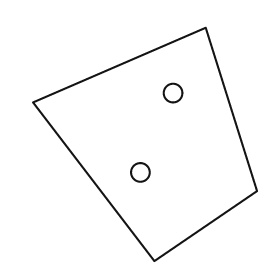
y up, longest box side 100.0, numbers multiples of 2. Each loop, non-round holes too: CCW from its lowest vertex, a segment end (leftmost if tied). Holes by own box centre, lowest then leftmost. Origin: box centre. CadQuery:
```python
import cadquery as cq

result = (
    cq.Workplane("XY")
    .moveTo(4.0, -50.0)
    .lineTo(48.0, -20.0)
    .lineTo(26.0, 50.0)
    .lineTo(-48.0, 18.0)
    .close()
    .moveTo(-2.0, -12.0)
    .circle(4.0)
    .moveTo(12.0, 22.0)
    .circle(4.0)
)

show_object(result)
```